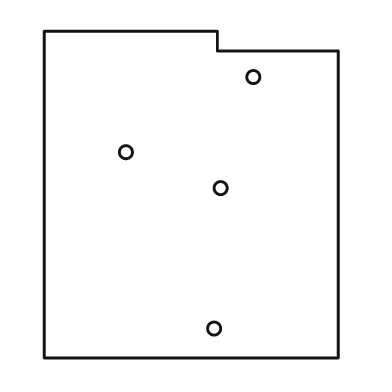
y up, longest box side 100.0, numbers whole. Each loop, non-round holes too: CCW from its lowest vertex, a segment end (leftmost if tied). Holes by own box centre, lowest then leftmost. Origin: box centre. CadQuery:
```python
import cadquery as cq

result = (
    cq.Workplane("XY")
    .moveTo(-45.0, -50.0)
    .lineTo(45.0, -50.0)
    .lineTo(45.0, 44.0)
    .lineTo(8.0, 44.0)
    .lineTo(8.0, 50.0)
    .lineTo(-45.0, 50.0)
    .close()
    .moveTo(7.0, -41.0)
    .circle(2.0)
    .moveTo(9.0, 2.0)
    .circle(2.0)
    .moveTo(-20.0, 13.0)
    .circle(2.0)
    .moveTo(19.0, 36.0)
    .circle(2.0)
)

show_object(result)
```